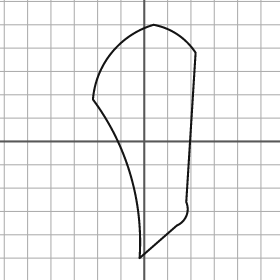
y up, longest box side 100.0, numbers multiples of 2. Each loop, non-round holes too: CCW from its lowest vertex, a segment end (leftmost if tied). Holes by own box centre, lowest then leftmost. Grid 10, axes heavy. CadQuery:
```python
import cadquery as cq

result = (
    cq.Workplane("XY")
    .moveTo(-2.0, -50.0)
    .lineTo(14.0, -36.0)
    .threePointArc((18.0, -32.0), (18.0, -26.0))
    .lineTo(22.0, 38.0)
    .threePointArc((14.0, 46.0), (4.0, 50.0))
    .threePointArc((-14.0, 38.0), (-22.0, 18.0))
    .threePointArc((-6.0, -14.0), (-2.0, -50.0))
    .close()
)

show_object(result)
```